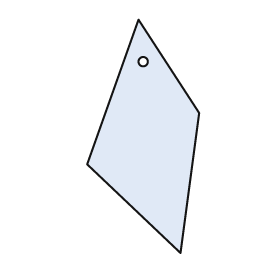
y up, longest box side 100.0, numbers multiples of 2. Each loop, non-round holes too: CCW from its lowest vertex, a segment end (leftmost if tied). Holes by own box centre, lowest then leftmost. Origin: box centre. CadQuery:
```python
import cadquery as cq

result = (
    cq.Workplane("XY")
    .moveTo(16.0, -50.0)
    .lineTo(24.0, 10.0)
    .lineTo(-2.0, 50.0)
    .lineTo(-24.0, -12.0)
    .close()
    .moveTo(0.0, 32.0)
    .circle(2.0)
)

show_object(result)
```